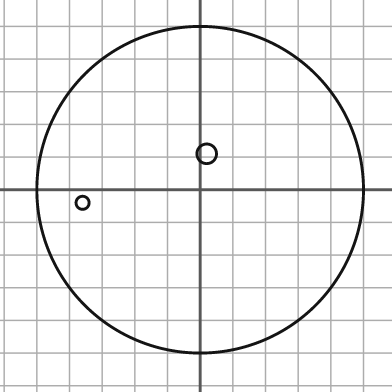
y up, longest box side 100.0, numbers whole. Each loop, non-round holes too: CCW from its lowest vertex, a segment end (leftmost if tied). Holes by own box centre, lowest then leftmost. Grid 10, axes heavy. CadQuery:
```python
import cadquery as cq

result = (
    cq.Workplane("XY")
    .moveTo(0.0, 0.0)
    .circle(50.0)
    .moveTo(-36.0, -4.0)
    .circle(2.0)
    .moveTo(2.0, 11.0)
    .circle(3.0)
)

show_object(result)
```